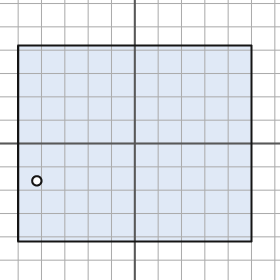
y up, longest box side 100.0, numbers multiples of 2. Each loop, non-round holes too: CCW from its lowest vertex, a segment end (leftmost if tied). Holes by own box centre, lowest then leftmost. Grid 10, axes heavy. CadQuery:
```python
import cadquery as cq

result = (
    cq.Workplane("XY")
    .moveTo(-50.0, -42.0)
    .lineTo(50.0, -42.0)
    .lineTo(50.0, 42.0)
    .lineTo(-50.0, 42.0)
    .close()
    .moveTo(-42.0, -16.0)
    .circle(2.0)
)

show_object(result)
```